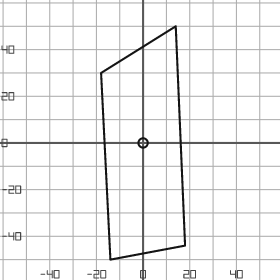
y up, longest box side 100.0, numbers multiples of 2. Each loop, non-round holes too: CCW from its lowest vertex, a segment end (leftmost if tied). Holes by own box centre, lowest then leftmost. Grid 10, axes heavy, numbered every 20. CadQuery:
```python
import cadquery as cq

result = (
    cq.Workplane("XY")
    .moveTo(-14.0, -50.0)
    .lineTo(18.0, -44.0)
    .lineTo(14.0, 50.0)
    .lineTo(-18.0, 30.0)
    .close()
    .moveTo(0.0, 0.0)
    .circle(2.0)
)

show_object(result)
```